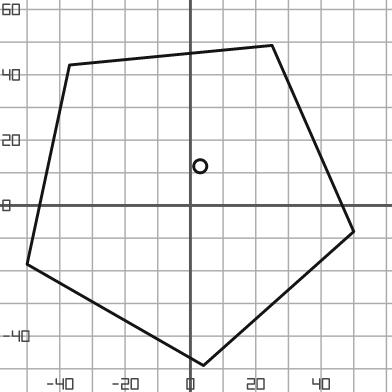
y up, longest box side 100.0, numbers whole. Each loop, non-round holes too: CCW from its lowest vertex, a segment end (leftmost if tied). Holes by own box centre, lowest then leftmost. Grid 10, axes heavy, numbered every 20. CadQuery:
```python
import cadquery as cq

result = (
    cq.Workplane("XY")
    .moveTo(4.0, -49.0)
    .lineTo(50.0, -8.0)
    .lineTo(25.0, 49.0)
    .lineTo(-37.0, 43.0)
    .lineTo(-50.0, -18.0)
    .close()
    .moveTo(3.0, 12.0)
    .circle(2.0)
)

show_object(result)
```